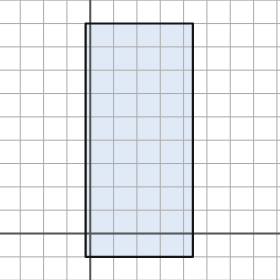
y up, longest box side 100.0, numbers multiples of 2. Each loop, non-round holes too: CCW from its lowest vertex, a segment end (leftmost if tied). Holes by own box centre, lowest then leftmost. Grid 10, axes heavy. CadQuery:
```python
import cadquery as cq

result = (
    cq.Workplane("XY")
    .moveTo(-2.0, -10.0)
    .lineTo(44.0, -10.0)
    .lineTo(44.0, 90.0)
    .lineTo(-2.0, 90.0)
    .close()
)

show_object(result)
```